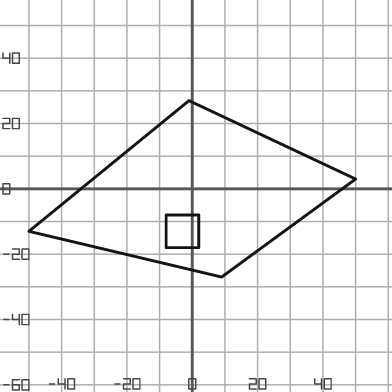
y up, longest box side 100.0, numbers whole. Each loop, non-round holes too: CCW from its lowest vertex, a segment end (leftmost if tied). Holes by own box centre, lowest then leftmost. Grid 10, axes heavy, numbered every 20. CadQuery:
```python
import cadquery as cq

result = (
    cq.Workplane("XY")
    .moveTo(9.0, -27.0)
    .lineTo(50.0, 3.0)
    .lineTo(-1.0, 27.0)
    .lineTo(-50.0, -13.0)
    .close()
    .moveTo(-8.0, -18.0)
    .lineTo(2.0, -18.0)
    .lineTo(2.0, -8.0)
    .lineTo(-8.0, -8.0)
    .close()
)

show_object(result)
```